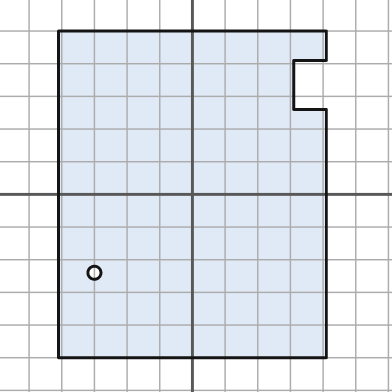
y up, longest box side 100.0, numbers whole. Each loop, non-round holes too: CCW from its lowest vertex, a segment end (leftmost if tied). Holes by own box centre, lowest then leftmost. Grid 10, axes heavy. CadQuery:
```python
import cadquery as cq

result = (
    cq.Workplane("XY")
    .moveTo(-41.0, -50.0)
    .lineTo(41.0, -50.0)
    .lineTo(41.0, 26.0)
    .lineTo(31.0, 26.0)
    .lineTo(31.0, 41.0)
    .lineTo(41.0, 41.0)
    .lineTo(41.0, 50.0)
    .lineTo(-41.0, 50.0)
    .close()
    .moveTo(-30.0, -24.0)
    .circle(2.0)
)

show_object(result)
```